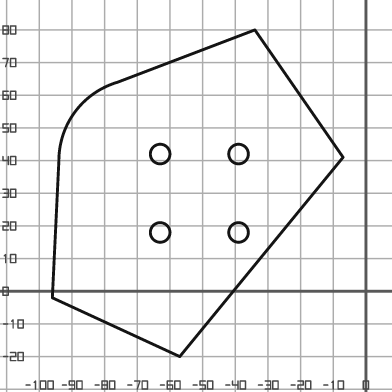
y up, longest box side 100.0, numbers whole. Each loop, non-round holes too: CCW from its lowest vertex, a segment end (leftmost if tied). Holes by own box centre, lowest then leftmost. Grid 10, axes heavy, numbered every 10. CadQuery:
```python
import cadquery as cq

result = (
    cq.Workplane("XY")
    .moveTo(-57.0, -20.0)
    .lineTo(-7.0, 41.0)
    .lineTo(-34.0, 80.0)
    .lineTo(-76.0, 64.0)
    .threePointArc((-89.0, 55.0), (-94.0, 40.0))
    .lineTo(-96.0, -2.0)
    .close()
    .moveTo(-63.0, 18.0)
    .circle(3.0)
    .moveTo(-39.0, 18.0)
    .circle(3.0)
    .moveTo(-63.0, 42.0)
    .circle(3.0)
    .moveTo(-39.0, 42.0)
    .circle(3.0)
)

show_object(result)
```